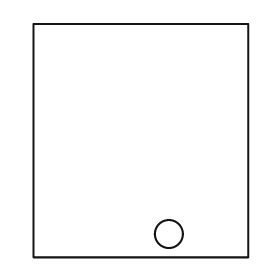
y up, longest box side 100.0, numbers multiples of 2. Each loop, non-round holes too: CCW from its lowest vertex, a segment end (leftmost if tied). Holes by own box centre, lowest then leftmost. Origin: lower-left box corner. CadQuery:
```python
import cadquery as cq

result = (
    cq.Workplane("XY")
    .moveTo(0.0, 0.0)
    .lineTo(92.0, 0.0)
    .lineTo(92.0, 100.0)
    .lineTo(0.0, 100.0)
    .close()
    .moveTo(58.0, 10.0)
    .circle(6.0)
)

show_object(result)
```